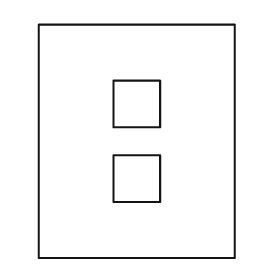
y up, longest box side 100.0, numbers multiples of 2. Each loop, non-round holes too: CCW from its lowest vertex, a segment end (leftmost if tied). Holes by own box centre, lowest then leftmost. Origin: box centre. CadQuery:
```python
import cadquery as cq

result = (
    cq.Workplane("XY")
    .moveTo(-42.0, -50.0)
    .lineTo(42.0, -50.0)
    .lineTo(42.0, 50.0)
    .lineTo(-42.0, 50.0)
    .close()
    .moveTo(-10.0, -26.0)
    .lineTo(10.0, -26.0)
    .lineTo(10.0, -6.0)
    .lineTo(-10.0, -6.0)
    .close()
    .moveTo(-10.0, 6.0)
    .lineTo(10.0, 6.0)
    .lineTo(10.0, 26.0)
    .lineTo(-10.0, 26.0)
    .close()
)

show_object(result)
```